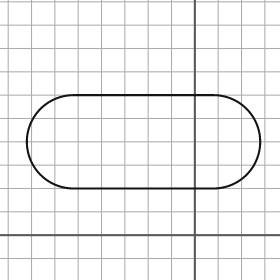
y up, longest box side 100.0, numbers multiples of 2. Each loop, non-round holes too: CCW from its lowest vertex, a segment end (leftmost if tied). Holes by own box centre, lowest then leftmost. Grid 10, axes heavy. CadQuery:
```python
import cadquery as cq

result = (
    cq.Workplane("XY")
    .moveTo(-52.0, 20.0)
    .lineTo(8.0, 20.0)
    .threePointArc((28.0, 40.0), (8.0, 60.0))
    .lineTo(-52.0, 60.0)
    .threePointArc((-72.0, 40.0), (-52.0, 20.0))
    .close()
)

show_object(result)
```